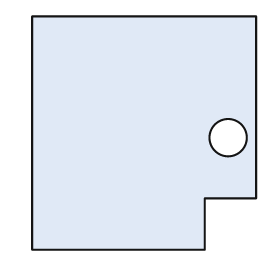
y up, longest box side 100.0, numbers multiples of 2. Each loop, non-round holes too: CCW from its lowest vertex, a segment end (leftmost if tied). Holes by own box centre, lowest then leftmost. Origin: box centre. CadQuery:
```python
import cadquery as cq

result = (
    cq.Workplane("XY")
    .moveTo(-48.0, -50.0)
    .lineTo(26.0, -50.0)
    .lineTo(26.0, -28.0)
    .lineTo(48.0, -28.0)
    .lineTo(48.0, 50.0)
    .lineTo(-48.0, 50.0)
    .close()
    .moveTo(36.0, -2.0)
    .circle(8.0)
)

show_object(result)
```